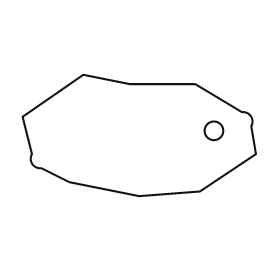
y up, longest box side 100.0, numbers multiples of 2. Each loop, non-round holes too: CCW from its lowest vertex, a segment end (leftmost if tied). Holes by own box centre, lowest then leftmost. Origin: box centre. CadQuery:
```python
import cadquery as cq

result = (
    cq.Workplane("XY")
    .moveTo(0.0, -26.0)
    .lineTo(26.0, -24.0)
    .lineTo(50.0, -8.0)
    .lineTo(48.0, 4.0)
    .threePointArc((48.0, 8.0), (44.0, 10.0))
    .lineTo(24.0, 22.0)
    .lineTo(-4.0, 22.0)
    .lineTo(-24.0, 26.0)
    .lineTo(-50.0, 8.0)
    .lineTo(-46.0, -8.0)
    .threePointArc((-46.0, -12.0), (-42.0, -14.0))
    .lineTo(-30.0, -20.0)
    .close()
    .moveTo(32.0, 2.0)
    .circle(4.0)
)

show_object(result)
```